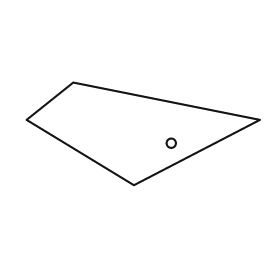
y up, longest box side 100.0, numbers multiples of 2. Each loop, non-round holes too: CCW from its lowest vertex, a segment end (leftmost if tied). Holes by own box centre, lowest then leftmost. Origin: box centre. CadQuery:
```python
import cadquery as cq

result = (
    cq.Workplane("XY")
    .moveTo(-4.0, -22.0)
    .lineTo(50.0, 6.0)
    .lineTo(-30.0, 22.0)
    .lineTo(-50.0, 6.0)
    .close()
    .moveTo(12.0, -4.0)
    .circle(2.0)
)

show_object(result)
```